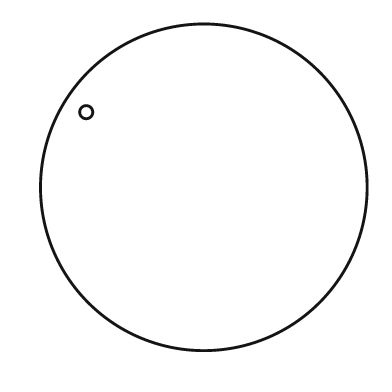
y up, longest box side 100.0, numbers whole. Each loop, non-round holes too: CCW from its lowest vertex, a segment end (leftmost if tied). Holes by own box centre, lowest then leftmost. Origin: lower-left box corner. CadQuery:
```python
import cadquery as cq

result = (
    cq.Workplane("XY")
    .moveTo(50.0, 50.0)
    .circle(50.0)
    .moveTo(14.0, 73.0)
    .circle(2.0)
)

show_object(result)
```